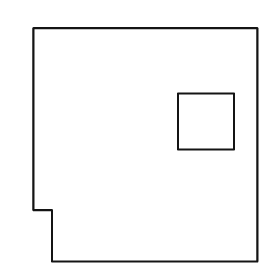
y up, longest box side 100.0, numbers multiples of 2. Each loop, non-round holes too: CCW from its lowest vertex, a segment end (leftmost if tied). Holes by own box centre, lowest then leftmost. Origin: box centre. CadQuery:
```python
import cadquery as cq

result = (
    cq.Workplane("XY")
    .moveTo(-40.0, -50.0)
    .lineTo(48.0, -50.0)
    .lineTo(48.0, 50.0)
    .lineTo(-48.0, 50.0)
    .lineTo(-48.0, -28.0)
    .lineTo(-40.0, -28.0)
    .close()
    .moveTo(14.0, -2.0)
    .lineTo(38.0, -2.0)
    .lineTo(38.0, 22.0)
    .lineTo(14.0, 22.0)
    .close()
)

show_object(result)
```